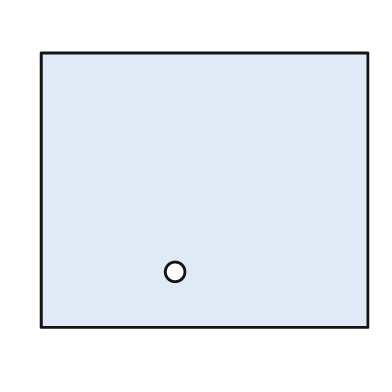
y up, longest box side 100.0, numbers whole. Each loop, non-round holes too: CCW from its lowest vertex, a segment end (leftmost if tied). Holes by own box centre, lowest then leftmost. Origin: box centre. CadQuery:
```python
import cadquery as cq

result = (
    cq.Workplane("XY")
    .moveTo(-50.0, -42.0)
    .lineTo(50.0, -42.0)
    .lineTo(50.0, 42.0)
    .lineTo(-50.0, 42.0)
    .close()
    .moveTo(-9.0, -25.0)
    .circle(3.0)
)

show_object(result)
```